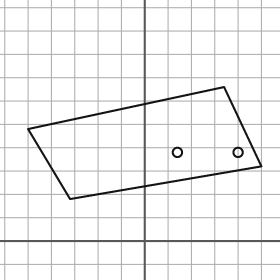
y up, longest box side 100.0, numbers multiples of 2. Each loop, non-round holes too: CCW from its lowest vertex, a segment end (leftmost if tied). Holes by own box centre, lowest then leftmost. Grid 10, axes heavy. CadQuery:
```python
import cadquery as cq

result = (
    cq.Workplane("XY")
    .moveTo(-32.0, 18.0)
    .lineTo(50.0, 32.0)
    .lineTo(34.0, 66.0)
    .lineTo(-50.0, 48.0)
    .close()
    .moveTo(14.0, 38.0)
    .circle(2.0)
    .moveTo(40.0, 38.0)
    .circle(2.0)
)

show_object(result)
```